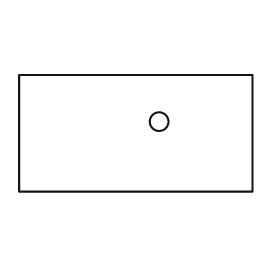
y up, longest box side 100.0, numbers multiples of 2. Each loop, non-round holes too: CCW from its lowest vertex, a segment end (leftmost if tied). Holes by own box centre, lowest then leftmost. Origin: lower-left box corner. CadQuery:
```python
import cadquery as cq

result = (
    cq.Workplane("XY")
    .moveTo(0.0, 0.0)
    .lineTo(100.0, 0.0)
    .lineTo(100.0, 50.0)
    .lineTo(0.0, 50.0)
    .close()
    .moveTo(60.0, 30.0)
    .circle(4.0)
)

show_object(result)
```